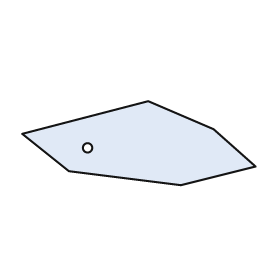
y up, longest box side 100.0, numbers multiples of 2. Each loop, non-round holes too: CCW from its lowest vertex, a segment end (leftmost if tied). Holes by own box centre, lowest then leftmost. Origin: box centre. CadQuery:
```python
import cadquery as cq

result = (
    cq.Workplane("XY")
    .moveTo(18.0, -18.0)
    .lineTo(50.0, -10.0)
    .lineTo(32.0, 6.0)
    .lineTo(4.0, 18.0)
    .lineTo(-50.0, 4.0)
    .lineTo(-30.0, -12.0)
    .close()
    .moveTo(-22.0, -2.0)
    .circle(2.0)
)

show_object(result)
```